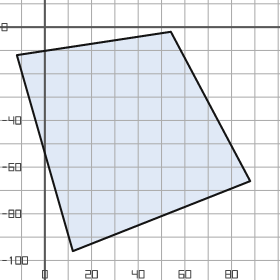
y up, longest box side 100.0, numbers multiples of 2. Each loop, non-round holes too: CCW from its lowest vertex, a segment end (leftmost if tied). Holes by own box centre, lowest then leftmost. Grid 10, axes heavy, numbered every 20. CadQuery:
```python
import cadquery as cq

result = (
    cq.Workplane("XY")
    .moveTo(12.0, -96.0)
    .lineTo(88.0, -66.0)
    .lineTo(54.0, -2.0)
    .lineTo(-12.0, -12.0)
    .close()
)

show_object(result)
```